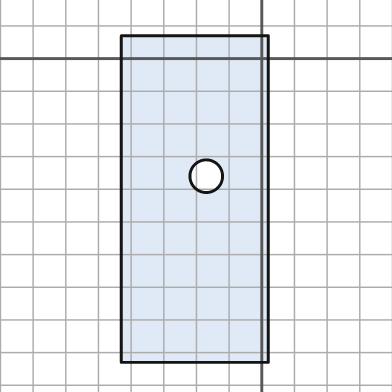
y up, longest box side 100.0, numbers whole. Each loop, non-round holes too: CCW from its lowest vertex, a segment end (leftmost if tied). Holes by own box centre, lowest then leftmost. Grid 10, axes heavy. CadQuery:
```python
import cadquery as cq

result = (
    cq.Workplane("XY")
    .moveTo(-43.0, -93.0)
    .lineTo(2.0, -93.0)
    .lineTo(2.0, 7.0)
    .lineTo(-43.0, 7.0)
    .close()
    .moveTo(-17.0, -36.0)
    .circle(5.0)
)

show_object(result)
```